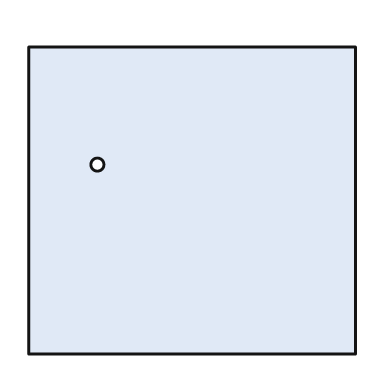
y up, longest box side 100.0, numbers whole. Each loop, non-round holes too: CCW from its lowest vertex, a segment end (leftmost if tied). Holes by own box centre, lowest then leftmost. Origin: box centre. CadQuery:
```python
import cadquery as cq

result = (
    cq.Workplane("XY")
    .moveTo(-50.0, -47.0)
    .lineTo(50.0, -47.0)
    .lineTo(50.0, 47.0)
    .lineTo(-50.0, 47.0)
    .close()
    .moveTo(-29.0, 11.0)
    .circle(2.0)
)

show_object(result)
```